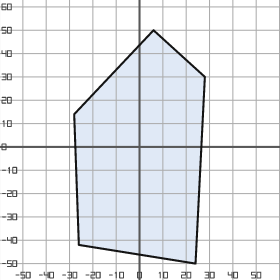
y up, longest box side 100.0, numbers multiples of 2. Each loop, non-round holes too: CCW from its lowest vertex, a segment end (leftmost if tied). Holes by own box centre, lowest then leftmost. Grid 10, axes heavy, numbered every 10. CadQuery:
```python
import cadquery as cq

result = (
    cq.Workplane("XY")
    .moveTo(24.0, -50.0)
    .lineTo(28.0, 30.0)
    .lineTo(6.0, 50.0)
    .lineTo(-28.0, 14.0)
    .lineTo(-26.0, -42.0)
    .close()
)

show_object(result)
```